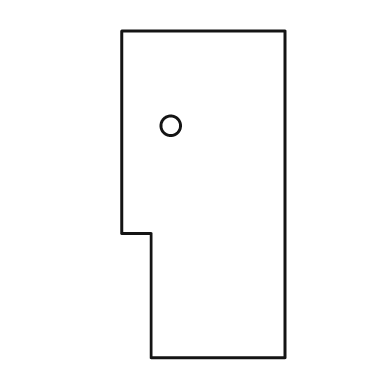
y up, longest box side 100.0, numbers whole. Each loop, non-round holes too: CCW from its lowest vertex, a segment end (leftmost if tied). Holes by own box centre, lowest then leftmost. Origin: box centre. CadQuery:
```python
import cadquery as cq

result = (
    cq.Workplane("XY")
    .moveTo(-16.0, -50.0)
    .lineTo(25.0, -50.0)
    .lineTo(25.0, 50.0)
    .lineTo(-25.0, 50.0)
    .lineTo(-25.0, -12.0)
    .lineTo(-16.0, -12.0)
    .close()
    .moveTo(-10.0, 21.0)
    .circle(3.0)
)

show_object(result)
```